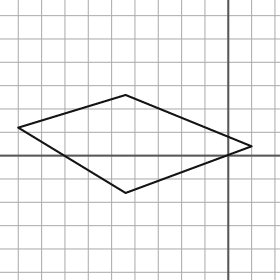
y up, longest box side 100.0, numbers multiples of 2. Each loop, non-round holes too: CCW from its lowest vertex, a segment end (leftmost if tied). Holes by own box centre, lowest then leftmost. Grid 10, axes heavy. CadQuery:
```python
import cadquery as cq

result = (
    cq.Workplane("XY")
    .moveTo(-44.0, -16.0)
    .lineTo(10.0, 4.0)
    .lineTo(-44.0, 26.0)
    .lineTo(-90.0, 12.0)
    .close()
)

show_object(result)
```